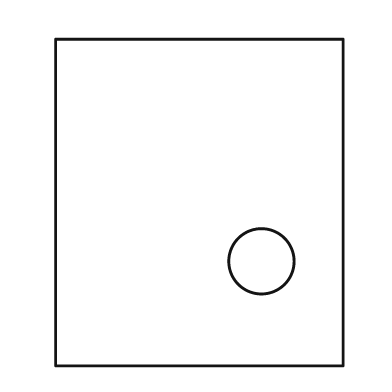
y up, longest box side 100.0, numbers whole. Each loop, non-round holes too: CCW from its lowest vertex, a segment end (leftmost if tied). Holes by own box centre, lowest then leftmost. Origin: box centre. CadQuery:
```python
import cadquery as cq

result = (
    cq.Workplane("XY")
    .moveTo(-44.0, -50.0)
    .lineTo(44.0, -50.0)
    .lineTo(44.0, 50.0)
    .lineTo(-44.0, 50.0)
    .close()
    .moveTo(19.0, -18.0)
    .circle(10.0)
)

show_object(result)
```